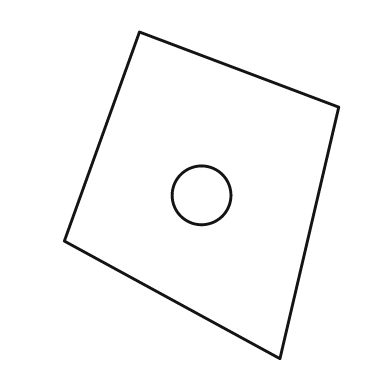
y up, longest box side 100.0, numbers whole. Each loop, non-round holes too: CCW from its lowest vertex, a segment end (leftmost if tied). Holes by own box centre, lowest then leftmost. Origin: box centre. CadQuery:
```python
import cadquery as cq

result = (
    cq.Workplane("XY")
    .moveTo(24.0, -50.0)
    .lineTo(42.0, 27.0)
    .lineTo(-19.0, 50.0)
    .lineTo(-42.0, -14.0)
    .close()
    .moveTo(0.0, 0.0)
    .circle(9.0)
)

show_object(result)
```